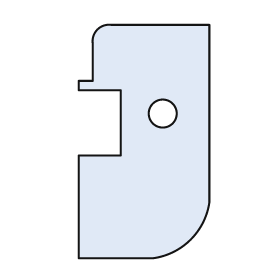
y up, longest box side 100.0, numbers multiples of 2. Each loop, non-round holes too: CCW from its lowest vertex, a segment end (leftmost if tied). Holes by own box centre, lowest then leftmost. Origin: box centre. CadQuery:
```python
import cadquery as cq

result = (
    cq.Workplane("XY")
    .moveTo(-28.0, -50.0)
    .lineTo(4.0, -50.0)
    .threePointArc((20.0, -42.0), (28.0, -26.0))
    .lineTo(28.0, 50.0)
    .lineTo(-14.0, 50.0)
    .threePointArc((-20.0, 48.0), (-22.0, 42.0))
    .lineTo(-22.0, 26.0)
    .lineTo(-28.0, 26.0)
    .lineTo(-28.0, 22.0)
    .lineTo(-10.0, 22.0)
    .lineTo(-10.0, -6.0)
    .lineTo(-28.0, -6.0)
    .close()
    .moveTo(8.0, 12.0)
    .circle(6.0)
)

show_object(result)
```